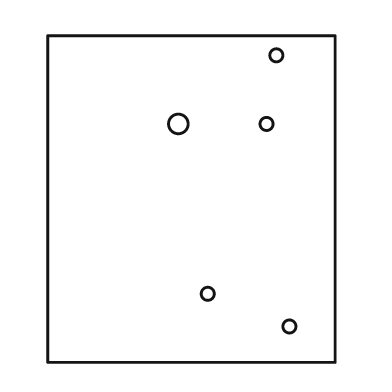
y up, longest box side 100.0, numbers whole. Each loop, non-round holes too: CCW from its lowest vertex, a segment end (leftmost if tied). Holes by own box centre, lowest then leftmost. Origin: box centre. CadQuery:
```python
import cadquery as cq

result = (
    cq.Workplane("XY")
    .moveTo(-44.0, -50.0)
    .lineTo(44.0, -50.0)
    .lineTo(44.0, 50.0)
    .lineTo(-44.0, 50.0)
    .close()
    .moveTo(30.0, -39.0)
    .circle(2.0)
    .moveTo(5.0, -29.0)
    .circle(2.0)
    .moveTo(-4.0, 23.0)
    .circle(3.0)
    .moveTo(23.0, 23.0)
    .circle(2.0)
    .moveTo(26.0, 44.0)
    .circle(2.0)
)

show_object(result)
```